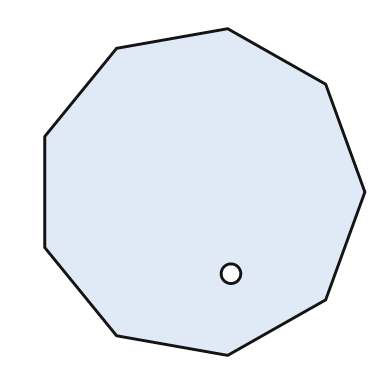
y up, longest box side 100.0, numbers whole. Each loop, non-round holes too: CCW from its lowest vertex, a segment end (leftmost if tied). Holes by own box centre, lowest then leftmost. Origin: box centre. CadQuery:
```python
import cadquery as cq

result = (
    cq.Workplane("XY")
    .moveTo(7.0, -50.0)
    .lineTo(37.0, -33.0)
    .lineTo(49.0, 0.0)
    .lineTo(37.0, 33.0)
    .lineTo(7.0, 50.0)
    .lineTo(-27.0, 44.0)
    .lineTo(-49.0, 17.0)
    .lineTo(-49.0, -17.0)
    .lineTo(-27.0, -44.0)
    .close()
    .moveTo(8.0, -25.0)
    .circle(3.0)
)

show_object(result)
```